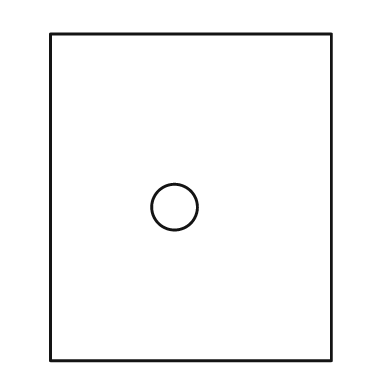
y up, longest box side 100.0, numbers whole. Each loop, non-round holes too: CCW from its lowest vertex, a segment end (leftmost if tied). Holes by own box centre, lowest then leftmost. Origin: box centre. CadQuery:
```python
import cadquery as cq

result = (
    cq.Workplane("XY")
    .moveTo(-43.0, -50.0)
    .lineTo(43.0, -50.0)
    .lineTo(43.0, 50.0)
    .lineTo(-43.0, 50.0)
    .close()
    .moveTo(-5.0, -3.0)
    .circle(7.0)
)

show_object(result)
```